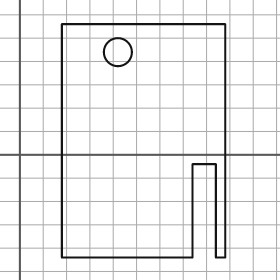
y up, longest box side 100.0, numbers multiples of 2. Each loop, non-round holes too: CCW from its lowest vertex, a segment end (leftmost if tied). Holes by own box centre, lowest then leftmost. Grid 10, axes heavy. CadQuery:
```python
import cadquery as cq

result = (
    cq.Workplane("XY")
    .moveTo(18.0, -44.0)
    .lineTo(74.0, -44.0)
    .lineTo(74.0, -4.0)
    .lineTo(84.0, -4.0)
    .lineTo(84.0, -44.0)
    .lineTo(88.0, -44.0)
    .lineTo(88.0, 56.0)
    .lineTo(18.0, 56.0)
    .close()
    .moveTo(42.0, 44.0)
    .circle(6.0)
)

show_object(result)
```